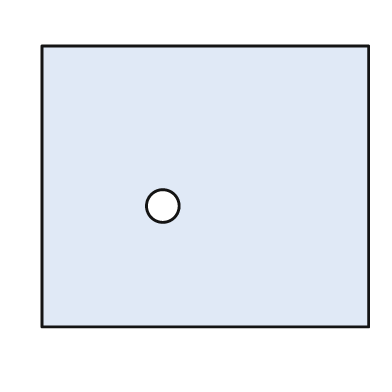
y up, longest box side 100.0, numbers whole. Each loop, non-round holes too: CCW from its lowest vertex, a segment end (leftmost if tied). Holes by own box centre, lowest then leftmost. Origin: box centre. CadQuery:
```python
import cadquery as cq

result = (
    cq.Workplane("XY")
    .moveTo(-50.0, -43.0)
    .lineTo(50.0, -43.0)
    .lineTo(50.0, 43.0)
    .lineTo(-50.0, 43.0)
    .close()
    .moveTo(-13.0, -6.0)
    .circle(5.0)
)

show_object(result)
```